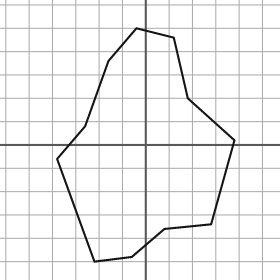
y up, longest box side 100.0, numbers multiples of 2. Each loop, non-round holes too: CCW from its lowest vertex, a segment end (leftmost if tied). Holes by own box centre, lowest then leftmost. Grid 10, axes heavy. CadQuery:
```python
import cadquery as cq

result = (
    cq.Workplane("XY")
    .moveTo(-22.0, -50.0)
    .lineTo(-6.0, -48.0)
    .lineTo(8.0, -36.0)
    .lineTo(28.0, -34.0)
    .lineTo(38.0, 2.0)
    .lineTo(18.0, 20.0)
    .lineTo(12.0, 46.0)
    .lineTo(-4.0, 50.0)
    .lineTo(-16.0, 36.0)
    .lineTo(-26.0, 8.0)
    .lineTo(-38.0, -6.0)
    .close()
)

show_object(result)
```